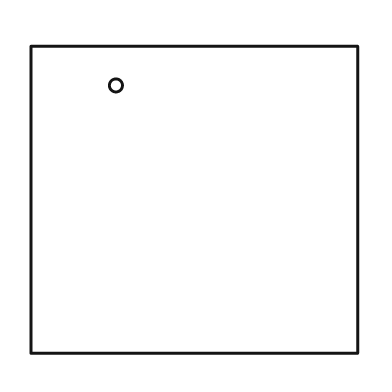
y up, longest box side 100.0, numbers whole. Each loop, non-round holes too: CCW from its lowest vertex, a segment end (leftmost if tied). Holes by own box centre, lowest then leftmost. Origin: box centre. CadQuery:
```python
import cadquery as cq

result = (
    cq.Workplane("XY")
    .moveTo(-50.0, -47.0)
    .lineTo(50.0, -47.0)
    .lineTo(50.0, 47.0)
    .lineTo(-50.0, 47.0)
    .close()
    .moveTo(-24.0, 35.0)
    .circle(2.0)
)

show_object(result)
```